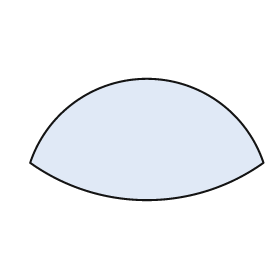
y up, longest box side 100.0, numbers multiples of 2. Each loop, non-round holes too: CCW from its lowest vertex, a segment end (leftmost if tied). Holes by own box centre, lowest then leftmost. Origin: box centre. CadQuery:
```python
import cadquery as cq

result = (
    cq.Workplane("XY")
    .moveTo(-50.0, -10.0)
    .threePointArc((0.0, -26.0), (50.0, -10.0))
    .threePointArc((0.0, 26.0), (-50.0, -10.0))
    .close()
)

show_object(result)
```